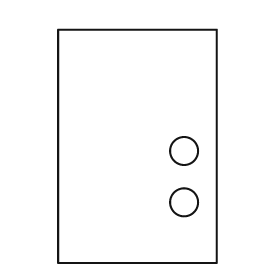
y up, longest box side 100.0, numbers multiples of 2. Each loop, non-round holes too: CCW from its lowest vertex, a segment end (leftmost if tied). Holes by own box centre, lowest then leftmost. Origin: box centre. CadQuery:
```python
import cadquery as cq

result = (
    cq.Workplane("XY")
    .moveTo(-34.0, -50.0)
    .lineTo(34.0, -50.0)
    .lineTo(34.0, 50.0)
    .lineTo(-34.0, 50.0)
    .close()
    .moveTo(20.0, -24.0)
    .circle(6.0)
    .moveTo(20.0, -2.0)
    .circle(6.0)
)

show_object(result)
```